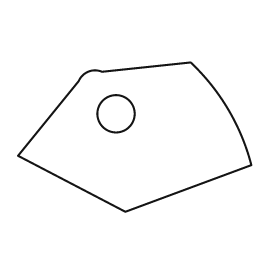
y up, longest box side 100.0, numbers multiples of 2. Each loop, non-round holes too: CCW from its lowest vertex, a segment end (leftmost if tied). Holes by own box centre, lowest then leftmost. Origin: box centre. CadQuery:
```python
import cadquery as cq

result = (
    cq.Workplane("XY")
    .moveTo(-4.0, -32.0)
    .lineTo(50.0, -12.0)
    .threePointArc((40.0, 12.0), (24.0, 32.0))
    .lineTo(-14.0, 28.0)
    .threePointArc((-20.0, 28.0), (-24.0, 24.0))
    .lineTo(-50.0, -8.0)
    .close()
    .moveTo(-8.0, 10.0)
    .circle(8.0)
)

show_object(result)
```